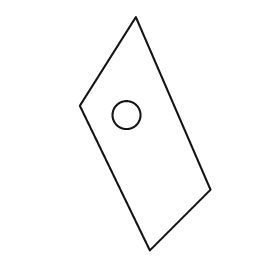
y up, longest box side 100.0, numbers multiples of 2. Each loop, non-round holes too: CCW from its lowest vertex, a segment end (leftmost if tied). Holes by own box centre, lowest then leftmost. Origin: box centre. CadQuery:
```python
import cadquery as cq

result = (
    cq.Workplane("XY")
    .moveTo(2.0, -50.0)
    .lineTo(28.0, -24.0)
    .lineTo(-4.0, 50.0)
    .lineTo(-28.0, 12.0)
    .close()
    .moveTo(-8.0, 8.0)
    .circle(6.0)
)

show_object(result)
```